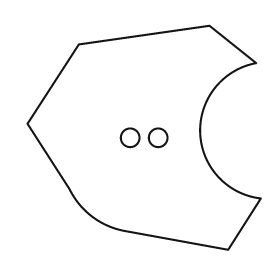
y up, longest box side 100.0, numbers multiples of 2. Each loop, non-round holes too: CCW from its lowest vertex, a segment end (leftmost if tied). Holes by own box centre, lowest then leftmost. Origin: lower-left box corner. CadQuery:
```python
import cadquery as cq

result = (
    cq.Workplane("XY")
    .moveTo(86.0, 0.0)
    .lineTo(100.0, 22.0)
    .threePointArc((74.0, 50.0), (98.0, 80.0))
    .lineTo(78.0, 96.0)
    .lineTo(22.0, 88.0)
    .lineTo(0.0, 54.0)
    .lineTo(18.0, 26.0)
    .threePointArc((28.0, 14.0), (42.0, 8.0))
    .close()
    .moveTo(44.0, 48.0)
    .circle(4.0)
    .moveTo(56.0, 48.0)
    .circle(4.0)
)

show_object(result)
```